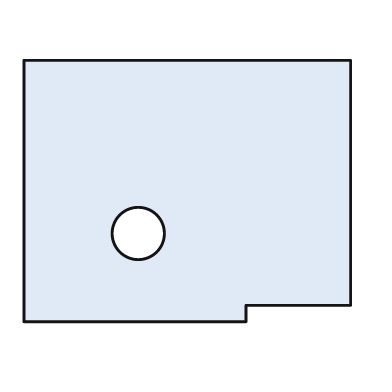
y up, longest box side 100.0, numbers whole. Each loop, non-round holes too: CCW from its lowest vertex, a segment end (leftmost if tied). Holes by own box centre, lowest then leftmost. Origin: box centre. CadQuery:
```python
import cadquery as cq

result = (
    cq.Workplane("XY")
    .moveTo(-50.0, -40.0)
    .lineTo(18.0, -40.0)
    .lineTo(18.0, -35.0)
    .lineTo(50.0, -35.0)
    .lineTo(50.0, 40.0)
    .lineTo(-50.0, 40.0)
    .close()
    .moveTo(-15.0, -13.0)
    .circle(8.0)
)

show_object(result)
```